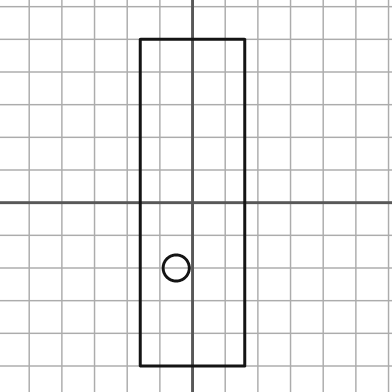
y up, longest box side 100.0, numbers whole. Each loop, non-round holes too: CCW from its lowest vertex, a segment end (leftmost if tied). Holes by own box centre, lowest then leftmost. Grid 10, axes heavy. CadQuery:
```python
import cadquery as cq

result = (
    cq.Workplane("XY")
    .moveTo(-16.0, -50.0)
    .lineTo(16.0, -50.0)
    .lineTo(16.0, 50.0)
    .lineTo(-16.0, 50.0)
    .close()
    .moveTo(-5.0, -20.0)
    .circle(4.0)
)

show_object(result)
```